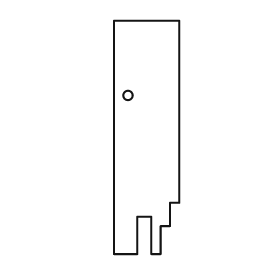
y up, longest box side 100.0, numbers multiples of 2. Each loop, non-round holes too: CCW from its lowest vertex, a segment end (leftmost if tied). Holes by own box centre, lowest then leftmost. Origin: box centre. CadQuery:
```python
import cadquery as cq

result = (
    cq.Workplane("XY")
    .moveTo(-14.0, -50.0)
    .lineTo(-4.0, -50.0)
    .lineTo(-4.0, -34.0)
    .lineTo(2.0, -34.0)
    .lineTo(2.0, -50.0)
    .lineTo(6.0, -50.0)
    .lineTo(6.0, -38.0)
    .lineTo(10.0, -38.0)
    .lineTo(10.0, -28.0)
    .lineTo(14.0, -28.0)
    .lineTo(14.0, 50.0)
    .lineTo(-14.0, 50.0)
    .close()
    .moveTo(-8.0, 18.0)
    .circle(2.0)
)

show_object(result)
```